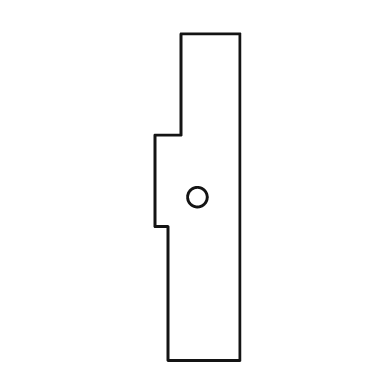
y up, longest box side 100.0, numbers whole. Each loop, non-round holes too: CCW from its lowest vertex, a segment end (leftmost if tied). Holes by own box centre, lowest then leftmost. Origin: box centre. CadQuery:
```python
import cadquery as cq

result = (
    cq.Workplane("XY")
    .moveTo(-9.0, -50.0)
    .lineTo(13.0, -50.0)
    .lineTo(13.0, 50.0)
    .lineTo(-5.0, 50.0)
    .lineTo(-5.0, 19.0)
    .lineTo(-13.0, 19.0)
    .lineTo(-13.0, -9.0)
    .lineTo(-9.0, -9.0)
    .close()
    .moveTo(0.0, 0.0)
    .circle(3.0)
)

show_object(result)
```